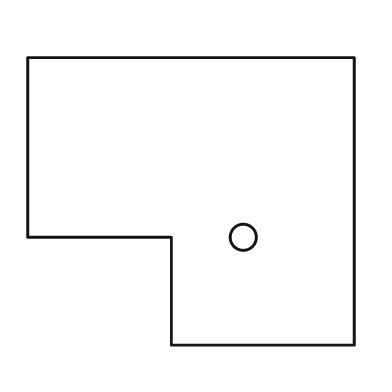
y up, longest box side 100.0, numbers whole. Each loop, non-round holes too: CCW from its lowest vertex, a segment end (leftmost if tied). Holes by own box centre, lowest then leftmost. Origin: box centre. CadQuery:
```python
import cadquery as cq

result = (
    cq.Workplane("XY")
    .moveTo(-6.0, -44.0)
    .lineTo(50.0, -44.0)
    .lineTo(50.0, 44.0)
    .lineTo(-50.0, 44.0)
    .lineTo(-50.0, -11.0)
    .lineTo(-6.0, -11.0)
    .close()
    .moveTo(16.0, -11.0)
    .circle(4.0)
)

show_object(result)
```